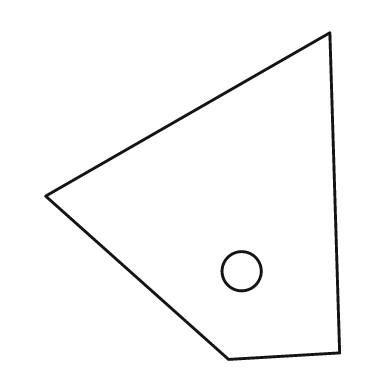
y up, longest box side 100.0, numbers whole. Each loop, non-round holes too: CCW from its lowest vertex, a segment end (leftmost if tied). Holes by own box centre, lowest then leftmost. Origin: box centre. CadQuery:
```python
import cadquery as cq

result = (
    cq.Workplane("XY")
    .moveTo(11.0, -50.0)
    .lineTo(45.0, -48.0)
    .lineTo(42.0, 50.0)
    .lineTo(-45.0, 0.0)
    .close()
    .moveTo(15.0, -23.0)
    .circle(6.0)
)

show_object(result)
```